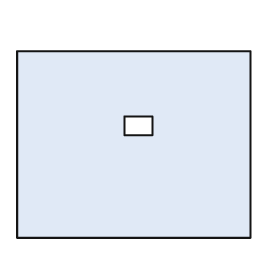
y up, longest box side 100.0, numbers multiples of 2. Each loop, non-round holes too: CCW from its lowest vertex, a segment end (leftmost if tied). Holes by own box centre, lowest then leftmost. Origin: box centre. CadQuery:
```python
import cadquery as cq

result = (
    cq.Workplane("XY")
    .moveTo(-50.0, -40.0)
    .lineTo(50.0, -40.0)
    .lineTo(50.0, 40.0)
    .lineTo(-50.0, 40.0)
    .close()
    .moveTo(-4.0, 4.0)
    .lineTo(8.0, 4.0)
    .lineTo(8.0, 12.0)
    .lineTo(-4.0, 12.0)
    .close()
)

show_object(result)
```